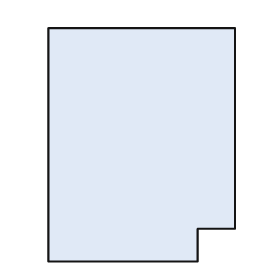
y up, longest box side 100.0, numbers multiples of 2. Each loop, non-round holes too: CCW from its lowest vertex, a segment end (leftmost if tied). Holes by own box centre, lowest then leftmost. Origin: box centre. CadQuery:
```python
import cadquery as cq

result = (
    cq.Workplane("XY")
    .moveTo(-40.0, -50.0)
    .lineTo(24.0, -50.0)
    .lineTo(24.0, -36.0)
    .lineTo(40.0, -36.0)
    .lineTo(40.0, 50.0)
    .lineTo(-40.0, 50.0)
    .close()
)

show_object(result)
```